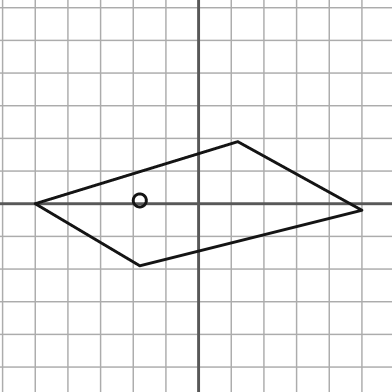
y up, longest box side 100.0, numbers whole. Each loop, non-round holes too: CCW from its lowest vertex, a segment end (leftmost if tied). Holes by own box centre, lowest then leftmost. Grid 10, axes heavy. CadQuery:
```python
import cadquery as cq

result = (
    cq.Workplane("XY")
    .moveTo(-18.0, -19.0)
    .lineTo(50.0, -2.0)
    .lineTo(12.0, 19.0)
    .lineTo(-50.0, 0.0)
    .close()
    .moveTo(-18.0, 1.0)
    .circle(2.0)
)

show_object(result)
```